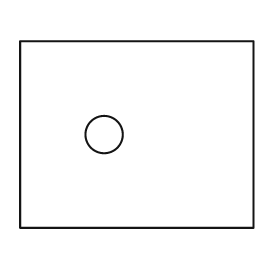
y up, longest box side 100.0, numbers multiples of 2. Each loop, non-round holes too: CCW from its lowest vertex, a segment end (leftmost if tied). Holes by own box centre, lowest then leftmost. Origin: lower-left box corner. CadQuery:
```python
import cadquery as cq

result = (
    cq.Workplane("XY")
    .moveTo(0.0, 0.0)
    .lineTo(100.0, 0.0)
    .lineTo(100.0, 80.0)
    .lineTo(0.0, 80.0)
    .close()
    .moveTo(36.0, 40.0)
    .circle(8.0)
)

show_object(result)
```